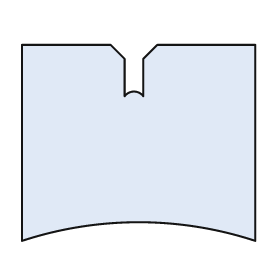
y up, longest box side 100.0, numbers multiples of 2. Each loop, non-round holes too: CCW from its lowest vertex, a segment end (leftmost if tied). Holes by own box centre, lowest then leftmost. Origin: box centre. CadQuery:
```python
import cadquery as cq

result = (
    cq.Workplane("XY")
    .moveTo(-50.0, -42.0)
    .threePointArc((0.0, -34.0), (50.0, -42.0))
    .lineTo(50.0, 42.0)
    .lineTo(8.0, 42.0)
    .lineTo(2.0, 36.0)
    .lineTo(2.0, 20.0)
    .threePointArc((-2.0, 22.0), (-6.0, 20.0))
    .lineTo(-6.0, 36.0)
    .lineTo(-12.0, 42.0)
    .lineTo(-50.0, 42.0)
    .close()
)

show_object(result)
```